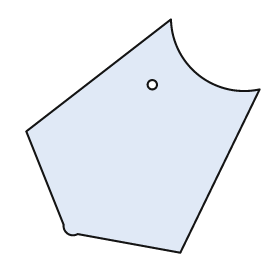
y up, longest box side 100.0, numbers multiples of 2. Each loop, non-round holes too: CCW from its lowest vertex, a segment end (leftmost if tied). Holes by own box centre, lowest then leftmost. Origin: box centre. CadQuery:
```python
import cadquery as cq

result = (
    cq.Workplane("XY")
    .moveTo(16.0, -50.0)
    .lineTo(50.0, 20.0)
    .threePointArc((24.0, 26.0), (12.0, 50.0))
    .lineTo(-50.0, 2.0)
    .lineTo(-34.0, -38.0)
    .threePointArc((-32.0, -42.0), (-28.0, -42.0))
    .close()
    .moveTo(4.0, 22.0)
    .circle(2.0)
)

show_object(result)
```